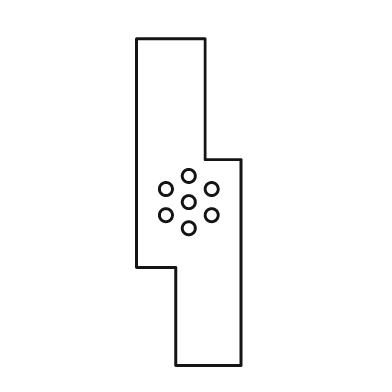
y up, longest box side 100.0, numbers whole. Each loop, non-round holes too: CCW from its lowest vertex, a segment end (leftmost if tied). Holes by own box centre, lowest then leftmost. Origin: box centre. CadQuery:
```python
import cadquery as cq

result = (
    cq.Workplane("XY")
    .moveTo(-4.0, -50.0)
    .lineTo(16.0, -50.0)
    .lineTo(16.0, 13.0)
    .lineTo(5.0, 13.0)
    .lineTo(5.0, 50.0)
    .lineTo(-16.0, 50.0)
    .lineTo(-16.0, -20.0)
    .lineTo(-4.0, -20.0)
    .close()
    .moveTo(0.0, -8.0)
    .circle(2.0)
    .moveTo(-7.0, -4.0)
    .circle(2.0)
    .moveTo(7.0, -4.0)
    .circle(2.0)
    .moveTo(0.0, 0.0)
    .circle(2.0)
    .moveTo(-7.0, 4.0)
    .circle(2.0)
    .moveTo(7.0, 4.0)
    .circle(2.0)
    .moveTo(0.0, 8.0)
    .circle(2.0)
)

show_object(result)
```